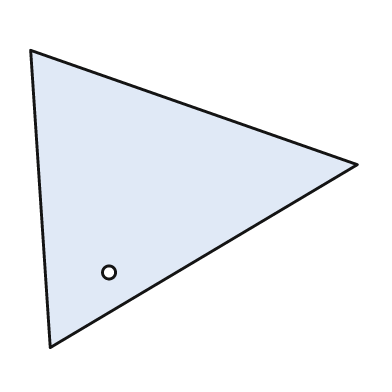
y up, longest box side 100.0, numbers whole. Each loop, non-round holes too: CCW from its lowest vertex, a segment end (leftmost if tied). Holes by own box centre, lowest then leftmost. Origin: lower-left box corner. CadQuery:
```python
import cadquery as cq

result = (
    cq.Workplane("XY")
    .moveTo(6.0, 0.0)
    .lineTo(100.0, 56.0)
    .lineTo(0.0, 91.0)
    .close()
    .moveTo(24.0, 23.0)
    .circle(2.0)
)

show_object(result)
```